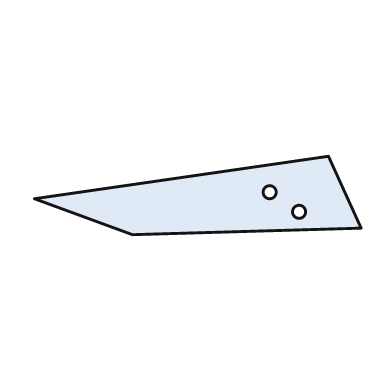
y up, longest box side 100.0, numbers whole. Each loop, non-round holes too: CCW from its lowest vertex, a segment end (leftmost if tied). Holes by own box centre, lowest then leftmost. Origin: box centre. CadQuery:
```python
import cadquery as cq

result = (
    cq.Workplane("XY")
    .moveTo(-20.0, -12.0)
    .lineTo(50.0, -10.0)
    .lineTo(40.0, 12.0)
    .lineTo(-50.0, -1.0)
    .close()
    .moveTo(31.0, -5.0)
    .circle(2.0)
    .moveTo(22.0, 1.0)
    .circle(2.0)
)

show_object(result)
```